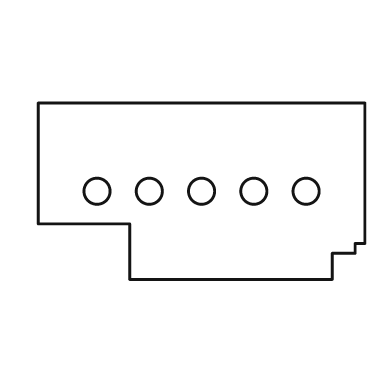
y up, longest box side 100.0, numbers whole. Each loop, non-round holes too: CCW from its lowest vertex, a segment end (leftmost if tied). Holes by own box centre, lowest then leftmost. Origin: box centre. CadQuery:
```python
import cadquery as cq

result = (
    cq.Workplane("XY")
    .moveTo(-22.0, -27.0)
    .lineTo(40.0, -27.0)
    .lineTo(40.0, -19.0)
    .lineTo(47.0, -19.0)
    .lineTo(47.0, -16.0)
    .lineTo(50.0, -16.0)
    .lineTo(50.0, 27.0)
    .lineTo(-50.0, 27.0)
    .lineTo(-50.0, -10.0)
    .lineTo(-22.0, -10.0)
    .close()
    .moveTo(-32.0, 0.0)
    .circle(4.0)
    .moveTo(-16.0, 0.0)
    .circle(4.0)
    .moveTo(0.0, 0.0)
    .circle(4.0)
    .moveTo(16.0, 0.0)
    .circle(4.0)
    .moveTo(32.0, 0.0)
    .circle(4.0)
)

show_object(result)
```